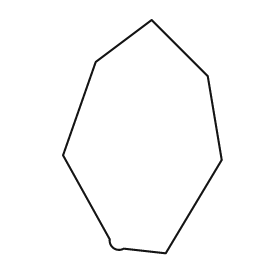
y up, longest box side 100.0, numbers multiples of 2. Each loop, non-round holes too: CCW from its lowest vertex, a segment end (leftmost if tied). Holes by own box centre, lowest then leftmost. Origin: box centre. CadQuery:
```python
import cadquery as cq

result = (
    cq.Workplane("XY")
    .moveTo(10.0, -50.0)
    .lineTo(34.0, -10.0)
    .lineTo(28.0, 26.0)
    .lineTo(4.0, 50.0)
    .lineTo(-20.0, 32.0)
    .lineTo(-34.0, -8.0)
    .lineTo(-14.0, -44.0)
    .threePointArc((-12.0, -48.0), (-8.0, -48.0))
    .close()
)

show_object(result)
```